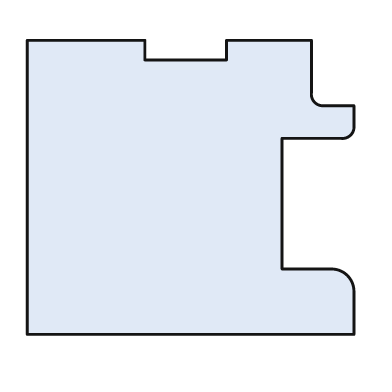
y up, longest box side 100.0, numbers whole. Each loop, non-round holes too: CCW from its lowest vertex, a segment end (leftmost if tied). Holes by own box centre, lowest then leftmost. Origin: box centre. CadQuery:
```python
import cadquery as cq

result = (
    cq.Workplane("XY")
    .moveTo(-50.0, -45.0)
    .lineTo(50.0, -45.0)
    .lineTo(50.0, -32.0)
    .threePointArc((48.0, -27.0), (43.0, -25.0))
    .lineTo(28.0, -25.0)
    .lineTo(28.0, 15.0)
    .lineTo(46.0, 15.0)
    .threePointArc((49.0, 16.0), (50.0, 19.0))
    .lineTo(50.0, 25.0)
    .lineTo(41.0, 25.0)
    .threePointArc((38.0, 26.0), (37.0, 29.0))
    .lineTo(37.0, 45.0)
    .lineTo(11.0, 45.0)
    .lineTo(11.0, 39.0)
    .lineTo(-14.0, 39.0)
    .lineTo(-14.0, 45.0)
    .lineTo(-50.0, 45.0)
    .close()
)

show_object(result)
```